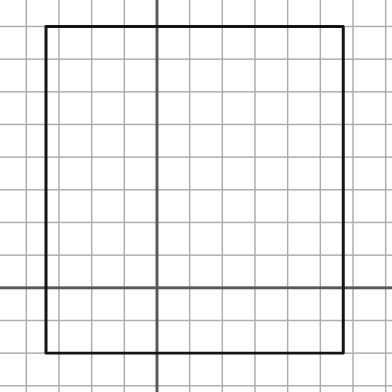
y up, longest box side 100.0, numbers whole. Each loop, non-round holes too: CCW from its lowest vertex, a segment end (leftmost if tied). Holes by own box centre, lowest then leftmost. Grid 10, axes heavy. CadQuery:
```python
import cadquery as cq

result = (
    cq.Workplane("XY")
    .moveTo(-34.0, -20.0)
    .lineTo(57.0, -20.0)
    .lineTo(57.0, 80.0)
    .lineTo(-34.0, 80.0)
    .close()
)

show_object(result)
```